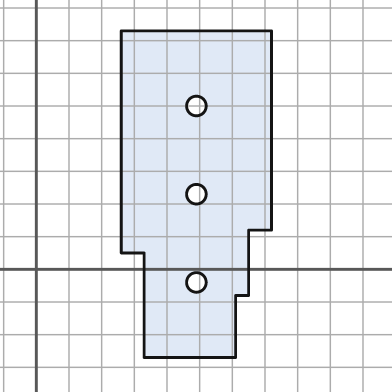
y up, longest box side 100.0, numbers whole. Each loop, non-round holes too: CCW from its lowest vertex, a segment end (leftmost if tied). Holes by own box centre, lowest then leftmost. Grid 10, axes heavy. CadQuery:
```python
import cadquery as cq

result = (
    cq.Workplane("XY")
    .moveTo(33.0, -27.0)
    .lineTo(61.0, -27.0)
    .lineTo(61.0, -8.0)
    .lineTo(65.0, -8.0)
    .lineTo(65.0, 12.0)
    .lineTo(72.0, 12.0)
    .lineTo(72.0, 73.0)
    .lineTo(26.0, 73.0)
    .lineTo(26.0, 5.0)
    .lineTo(33.0, 5.0)
    .close()
    .moveTo(49.0, -4.0)
    .circle(3.0)
    .moveTo(49.0, 23.0)
    .circle(3.0)
    .moveTo(49.0, 50.0)
    .circle(3.0)
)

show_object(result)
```